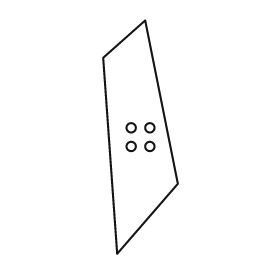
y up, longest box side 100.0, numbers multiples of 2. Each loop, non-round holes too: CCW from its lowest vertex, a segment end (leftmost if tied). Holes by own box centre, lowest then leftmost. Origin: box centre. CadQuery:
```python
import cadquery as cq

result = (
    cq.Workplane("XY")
    .moveTo(-10.0, -50.0)
    .lineTo(16.0, -20.0)
    .lineTo(2.0, 50.0)
    .lineTo(-16.0, 34.0)
    .close()
    .moveTo(-4.0, -4.0)
    .circle(2.0)
    .moveTo(4.0, -4.0)
    .circle(2.0)
    .moveTo(-4.0, 4.0)
    .circle(2.0)
    .moveTo(4.0, 4.0)
    .circle(2.0)
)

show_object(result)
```